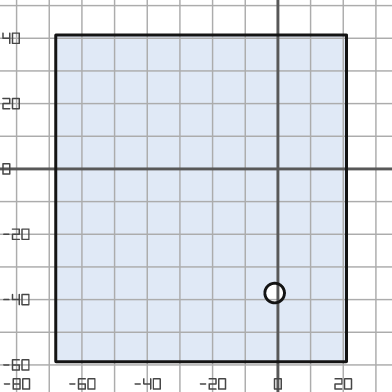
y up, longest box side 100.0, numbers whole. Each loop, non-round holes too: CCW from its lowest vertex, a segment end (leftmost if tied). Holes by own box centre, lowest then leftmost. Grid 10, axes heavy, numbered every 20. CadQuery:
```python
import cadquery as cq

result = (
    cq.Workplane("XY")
    .moveTo(-68.0, -59.0)
    .lineTo(21.0, -59.0)
    .lineTo(21.0, 41.0)
    .lineTo(-68.0, 41.0)
    .close()
    .moveTo(-1.0, -38.0)
    .circle(3.0)
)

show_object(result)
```